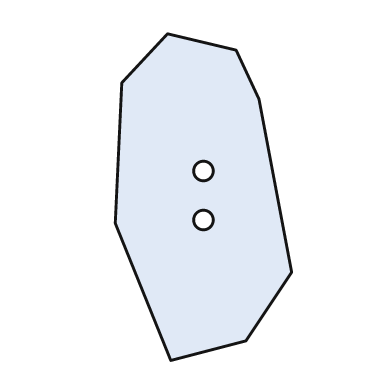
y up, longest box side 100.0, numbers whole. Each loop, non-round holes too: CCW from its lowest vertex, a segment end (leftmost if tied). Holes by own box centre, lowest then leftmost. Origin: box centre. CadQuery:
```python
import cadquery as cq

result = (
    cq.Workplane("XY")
    .moveTo(-10.0, -50.0)
    .lineTo(13.0, -44.0)
    .lineTo(27.0, -23.0)
    .lineTo(17.0, 30.0)
    .lineTo(10.0, 45.0)
    .lineTo(-11.0, 50.0)
    .lineTo(-25.0, 35.0)
    .lineTo(-27.0, -8.0)
    .close()
    .moveTo(0.0, -7.0)
    .circle(3.0)
    .moveTo(0.0, 8.0)
    .circle(3.0)
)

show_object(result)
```